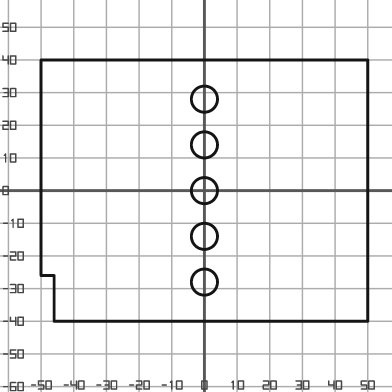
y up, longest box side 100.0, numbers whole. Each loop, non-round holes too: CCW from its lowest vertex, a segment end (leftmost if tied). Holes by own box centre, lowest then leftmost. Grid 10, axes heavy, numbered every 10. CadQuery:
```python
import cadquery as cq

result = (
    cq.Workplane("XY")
    .moveTo(-46.0, -40.0)
    .lineTo(50.0, -40.0)
    .lineTo(50.0, 40.0)
    .lineTo(-50.0, 40.0)
    .lineTo(-50.0, -26.0)
    .lineTo(-46.0, -26.0)
    .close()
    .moveTo(0.0, -28.0)
    .circle(4.0)
    .moveTo(0.0, -14.0)
    .circle(4.0)
    .moveTo(0.0, 0.0)
    .circle(4.0)
    .moveTo(0.0, 14.0)
    .circle(4.0)
    .moveTo(0.0, 28.0)
    .circle(4.0)
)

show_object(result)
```